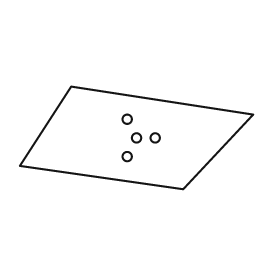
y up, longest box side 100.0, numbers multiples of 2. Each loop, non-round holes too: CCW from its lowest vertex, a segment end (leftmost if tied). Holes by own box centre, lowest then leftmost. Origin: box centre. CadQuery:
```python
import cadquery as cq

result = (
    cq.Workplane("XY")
    .moveTo(20.0, -22.0)
    .lineTo(50.0, 10.0)
    .lineTo(-28.0, 22.0)
    .lineTo(-50.0, -12.0)
    .close()
    .moveTo(-4.0, -8.0)
    .circle(2.0)
    .moveTo(0.0, 0.0)
    .circle(2.0)
    .moveTo(8.0, 0.0)
    .circle(2.0)
    .moveTo(-4.0, 8.0)
    .circle(2.0)
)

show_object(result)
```